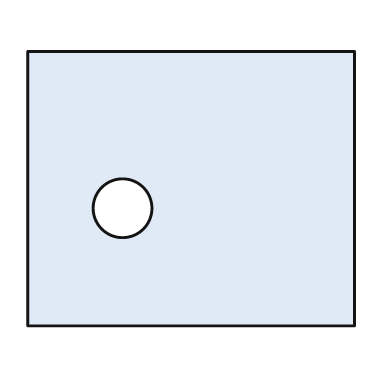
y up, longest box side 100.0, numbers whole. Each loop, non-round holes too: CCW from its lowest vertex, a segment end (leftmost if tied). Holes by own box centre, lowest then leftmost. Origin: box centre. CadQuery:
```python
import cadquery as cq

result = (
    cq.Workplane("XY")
    .moveTo(-50.0, -42.0)
    .lineTo(50.0, -42.0)
    .lineTo(50.0, 42.0)
    .lineTo(-50.0, 42.0)
    .close()
    .moveTo(-21.0, -6.0)
    .circle(9.0)
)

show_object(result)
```